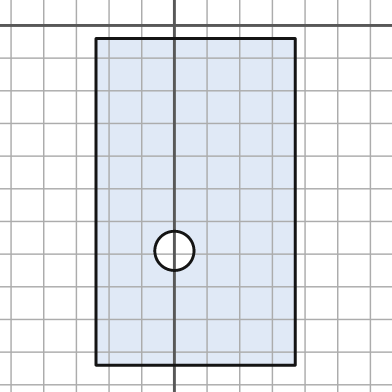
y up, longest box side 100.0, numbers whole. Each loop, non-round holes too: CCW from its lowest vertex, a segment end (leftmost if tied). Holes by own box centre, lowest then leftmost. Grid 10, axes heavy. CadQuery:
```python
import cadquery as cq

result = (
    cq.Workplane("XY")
    .moveTo(-24.0, -104.0)
    .lineTo(37.0, -104.0)
    .lineTo(37.0, -4.0)
    .lineTo(-24.0, -4.0)
    .close()
    .moveTo(0.0, -69.0)
    .circle(6.0)
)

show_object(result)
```